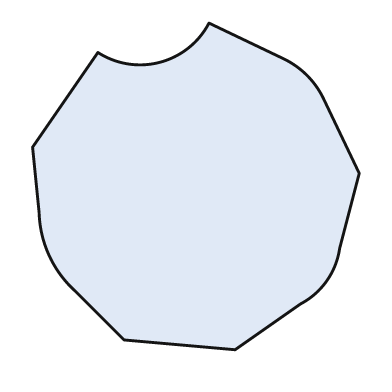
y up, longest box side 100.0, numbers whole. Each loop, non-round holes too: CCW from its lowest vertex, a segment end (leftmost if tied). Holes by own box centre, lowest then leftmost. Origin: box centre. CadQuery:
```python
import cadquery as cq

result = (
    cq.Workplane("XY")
    .moveTo(12.0, -50.0)
    .lineTo(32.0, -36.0)
    .threePointArc((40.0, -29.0), (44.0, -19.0))
    .lineTo(50.0, 4.0)
    .lineTo(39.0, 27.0)
    .threePointArc((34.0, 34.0), (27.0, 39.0))
    .lineTo(4.0, 50.0)
    .threePointArc((-11.0, 38.0), (-30.0, 41.0))
    .lineTo(-50.0, 12.0)
    .lineTo(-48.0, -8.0)
    .threePointArc((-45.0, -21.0), (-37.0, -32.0))
    .lineTo(-22.0, -47.0)
    .close()
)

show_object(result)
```